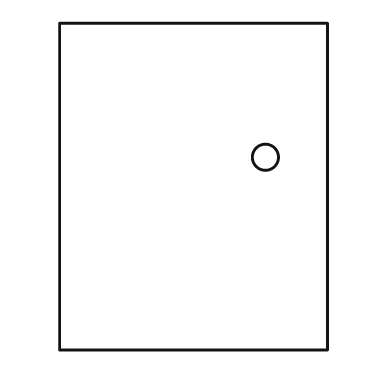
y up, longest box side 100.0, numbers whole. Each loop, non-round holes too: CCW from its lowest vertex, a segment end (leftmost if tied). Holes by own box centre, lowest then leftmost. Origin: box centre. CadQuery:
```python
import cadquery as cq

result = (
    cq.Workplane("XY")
    .moveTo(-41.0, -50.0)
    .lineTo(41.0, -50.0)
    .lineTo(41.0, 50.0)
    .lineTo(-41.0, 50.0)
    .close()
    .moveTo(22.0, 9.0)
    .circle(4.0)
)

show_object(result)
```